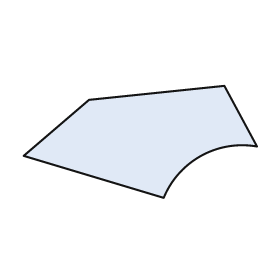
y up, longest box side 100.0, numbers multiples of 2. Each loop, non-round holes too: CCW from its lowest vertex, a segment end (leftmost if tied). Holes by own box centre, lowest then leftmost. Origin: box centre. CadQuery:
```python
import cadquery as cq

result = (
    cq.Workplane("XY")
    .moveTo(10.0, -24.0)
    .threePointArc((26.0, -6.0), (50.0, -2.0))
    .lineTo(36.0, 24.0)
    .lineTo(-22.0, 18.0)
    .lineTo(-50.0, -6.0)
    .close()
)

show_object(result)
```